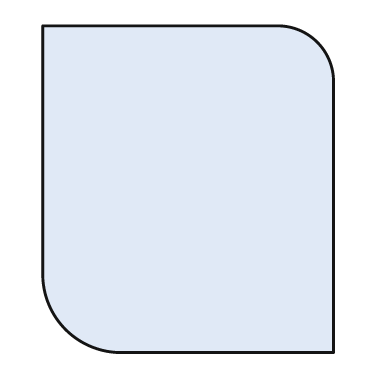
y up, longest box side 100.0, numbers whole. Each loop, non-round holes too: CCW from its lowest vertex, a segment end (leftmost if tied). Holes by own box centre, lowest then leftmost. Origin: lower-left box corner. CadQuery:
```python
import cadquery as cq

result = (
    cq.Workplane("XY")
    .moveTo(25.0, 0.0)
    .lineTo(89.0, 0.0)
    .lineTo(89.0, 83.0)
    .threePointArc((84.0, 95.0), (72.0, 100.0))
    .lineTo(0.0, 100.0)
    .lineTo(0.0, 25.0)
    .threePointArc((7.0, 7.0), (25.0, 0.0))
    .close()
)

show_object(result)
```